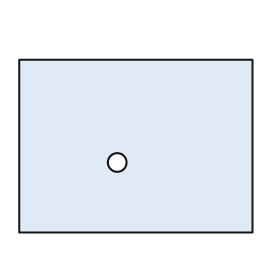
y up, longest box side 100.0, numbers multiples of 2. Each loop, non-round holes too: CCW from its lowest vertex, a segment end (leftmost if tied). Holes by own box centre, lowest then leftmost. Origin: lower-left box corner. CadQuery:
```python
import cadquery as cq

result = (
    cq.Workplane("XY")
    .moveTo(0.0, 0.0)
    .lineTo(100.0, 0.0)
    .lineTo(100.0, 74.0)
    .lineTo(0.0, 74.0)
    .close()
    .moveTo(42.0, 30.0)
    .circle(4.0)
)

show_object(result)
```